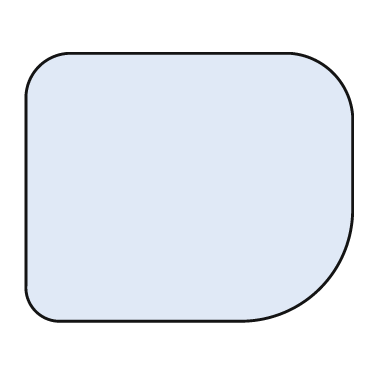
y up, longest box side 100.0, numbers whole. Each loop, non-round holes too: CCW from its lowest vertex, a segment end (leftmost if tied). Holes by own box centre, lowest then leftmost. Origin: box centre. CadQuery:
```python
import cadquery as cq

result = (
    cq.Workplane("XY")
    .moveTo(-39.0, -41.0)
    .lineTo(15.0, -41.0)
    .threePointArc((40.0, -31.0), (50.0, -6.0))
    .lineTo(50.0, 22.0)
    .threePointArc((44.0, 35.0), (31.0, 41.0))
    .lineTo(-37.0, 41.0)
    .threePointArc((-46.0, 37.0), (-50.0, 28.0))
    .lineTo(-50.0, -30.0)
    .threePointArc((-47.0, -38.0), (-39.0, -41.0))
    .close()
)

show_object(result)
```